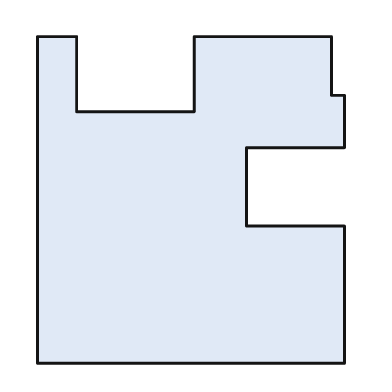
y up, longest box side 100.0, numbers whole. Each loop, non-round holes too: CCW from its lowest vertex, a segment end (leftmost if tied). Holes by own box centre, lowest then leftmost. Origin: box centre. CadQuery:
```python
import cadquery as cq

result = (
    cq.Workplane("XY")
    .moveTo(-47.0, -50.0)
    .lineTo(47.0, -50.0)
    .lineTo(47.0, -8.0)
    .lineTo(17.0, -8.0)
    .lineTo(17.0, 16.0)
    .lineTo(47.0, 16.0)
    .lineTo(47.0, 32.0)
    .lineTo(43.0, 32.0)
    .lineTo(43.0, 50.0)
    .lineTo(1.0, 50.0)
    .lineTo(1.0, 27.0)
    .lineTo(-35.0, 27.0)
    .lineTo(-35.0, 50.0)
    .lineTo(-47.0, 50.0)
    .close()
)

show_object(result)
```